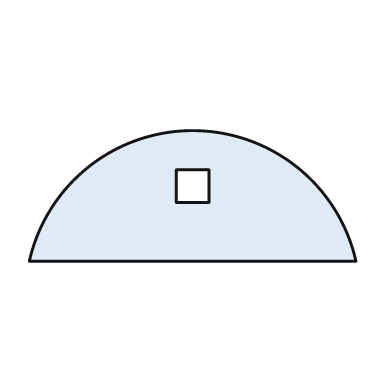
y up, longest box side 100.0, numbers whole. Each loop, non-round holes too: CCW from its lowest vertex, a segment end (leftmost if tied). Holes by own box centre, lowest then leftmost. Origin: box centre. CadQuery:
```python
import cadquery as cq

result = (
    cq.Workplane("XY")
    .moveTo(-50.0, -20.0)
    .lineTo(50.0, -20.0)
    .threePointArc((0.0, 20.0), (-50.0, -20.0))
    .close()
    .moveTo(-5.0, -2.0)
    .lineTo(5.0, -2.0)
    .lineTo(5.0, 8.0)
    .lineTo(-5.0, 8.0)
    .close()
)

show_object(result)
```